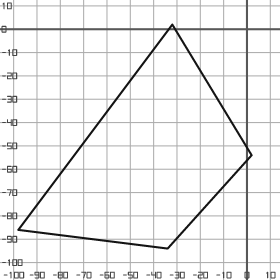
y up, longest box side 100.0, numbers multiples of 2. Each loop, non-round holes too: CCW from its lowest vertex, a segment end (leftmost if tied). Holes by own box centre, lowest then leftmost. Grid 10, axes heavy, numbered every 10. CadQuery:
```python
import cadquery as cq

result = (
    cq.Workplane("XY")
    .moveTo(-34.0, -94.0)
    .lineTo(2.0, -54.0)
    .lineTo(-32.0, 2.0)
    .lineTo(-98.0, -86.0)
    .close()
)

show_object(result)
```